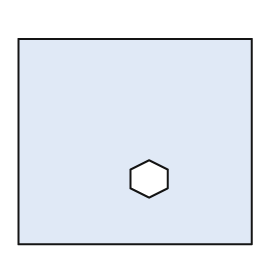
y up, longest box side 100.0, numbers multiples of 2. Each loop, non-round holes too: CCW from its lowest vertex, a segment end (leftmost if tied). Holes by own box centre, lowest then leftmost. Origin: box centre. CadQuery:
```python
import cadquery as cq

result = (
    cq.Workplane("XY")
    .moveTo(-50.0, -44.0)
    .lineTo(50.0, -44.0)
    .lineTo(50.0, 44.0)
    .lineTo(-50.0, 44.0)
    .close()
    .moveTo(6.0, -24.0)
    .lineTo(14.0, -20.0)
    .lineTo(14.0, -12.0)
    .lineTo(6.0, -8.0)
    .lineTo(-2.0, -12.0)
    .lineTo(-2.0, -20.0)
    .close()
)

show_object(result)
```